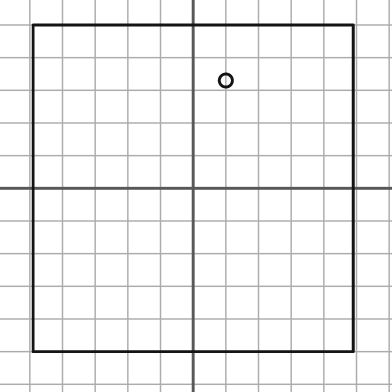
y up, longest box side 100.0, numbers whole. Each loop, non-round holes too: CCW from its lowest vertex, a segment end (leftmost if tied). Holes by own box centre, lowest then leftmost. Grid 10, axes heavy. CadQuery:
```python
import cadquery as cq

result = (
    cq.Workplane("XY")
    .moveTo(-49.0, -50.0)
    .lineTo(49.0, -50.0)
    .lineTo(49.0, 50.0)
    .lineTo(-49.0, 50.0)
    .close()
    .moveTo(10.0, 33.0)
    .circle(2.0)
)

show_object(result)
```